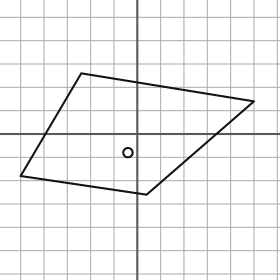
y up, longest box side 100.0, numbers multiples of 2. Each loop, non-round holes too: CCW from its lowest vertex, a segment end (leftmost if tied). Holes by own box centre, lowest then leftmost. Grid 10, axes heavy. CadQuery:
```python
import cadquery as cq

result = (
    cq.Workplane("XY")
    .moveTo(4.0, -26.0)
    .lineTo(50.0, 14.0)
    .lineTo(-24.0, 26.0)
    .lineTo(-50.0, -18.0)
    .close()
    .moveTo(-4.0, -8.0)
    .circle(2.0)
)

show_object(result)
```